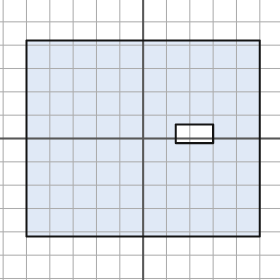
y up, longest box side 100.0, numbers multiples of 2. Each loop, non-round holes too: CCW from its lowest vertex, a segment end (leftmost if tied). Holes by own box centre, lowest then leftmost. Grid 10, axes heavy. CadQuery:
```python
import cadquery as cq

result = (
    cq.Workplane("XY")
    .moveTo(-50.0, -42.0)
    .lineTo(50.0, -42.0)
    .lineTo(50.0, 42.0)
    .lineTo(-50.0, 42.0)
    .close()
    .moveTo(14.0, -2.0)
    .lineTo(30.0, -2.0)
    .lineTo(30.0, 6.0)
    .lineTo(14.0, 6.0)
    .close()
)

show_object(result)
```